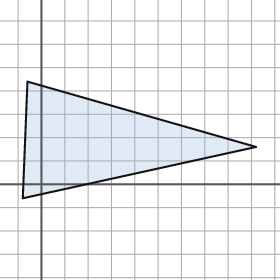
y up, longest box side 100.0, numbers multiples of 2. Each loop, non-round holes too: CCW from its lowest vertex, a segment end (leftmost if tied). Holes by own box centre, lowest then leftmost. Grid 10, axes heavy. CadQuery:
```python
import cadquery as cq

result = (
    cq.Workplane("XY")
    .moveTo(-8.0, -6.0)
    .lineTo(92.0, 16.0)
    .lineTo(-6.0, 44.0)
    .close()
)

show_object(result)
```